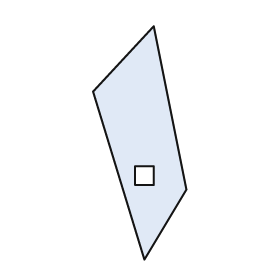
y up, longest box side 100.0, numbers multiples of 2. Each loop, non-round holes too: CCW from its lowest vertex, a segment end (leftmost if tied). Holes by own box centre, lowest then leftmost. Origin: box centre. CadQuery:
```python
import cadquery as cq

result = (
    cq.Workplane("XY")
    .moveTo(2.0, -50.0)
    .lineTo(20.0, -20.0)
    .lineTo(6.0, 50.0)
    .lineTo(-20.0, 22.0)
    .close()
    .moveTo(-2.0, -18.0)
    .lineTo(6.0, -18.0)
    .lineTo(6.0, -10.0)
    .lineTo(-2.0, -10.0)
    .close()
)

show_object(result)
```